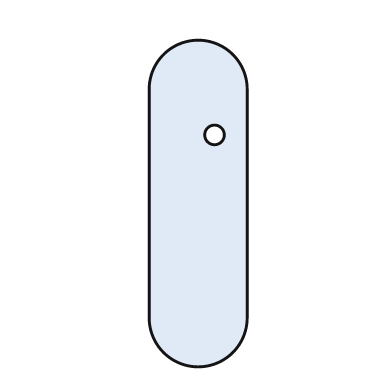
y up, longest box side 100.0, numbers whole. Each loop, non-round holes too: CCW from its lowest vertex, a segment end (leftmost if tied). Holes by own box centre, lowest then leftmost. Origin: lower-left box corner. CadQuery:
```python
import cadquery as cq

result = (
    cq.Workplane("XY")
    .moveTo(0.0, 15.0)
    .threePointArc((15.0, 0.0), (30.0, 15.0))
    .lineTo(30.0, 85.0)
    .threePointArc((15.0, 100.0), (0.0, 85.0))
    .close()
    .moveTo(20.0, 71.0)
    .circle(3.0)
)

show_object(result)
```